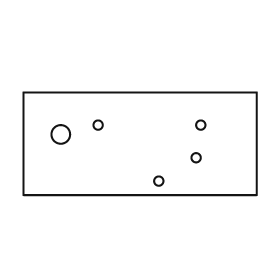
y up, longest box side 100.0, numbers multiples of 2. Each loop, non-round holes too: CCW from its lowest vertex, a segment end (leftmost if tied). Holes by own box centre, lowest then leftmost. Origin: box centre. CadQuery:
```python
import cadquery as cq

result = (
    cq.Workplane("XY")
    .moveTo(-50.0, -22.0)
    .lineTo(50.0, -22.0)
    .lineTo(50.0, 22.0)
    .lineTo(-50.0, 22.0)
    .close()
    .moveTo(8.0, -16.0)
    .circle(2.0)
    .moveTo(24.0, -6.0)
    .circle(2.0)
    .moveTo(-34.0, 4.0)
    .circle(4.0)
    .moveTo(-18.0, 8.0)
    .circle(2.0)
    .moveTo(26.0, 8.0)
    .circle(2.0)
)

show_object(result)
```